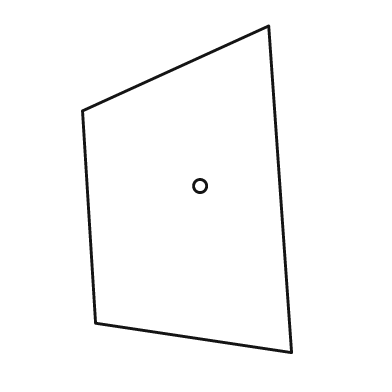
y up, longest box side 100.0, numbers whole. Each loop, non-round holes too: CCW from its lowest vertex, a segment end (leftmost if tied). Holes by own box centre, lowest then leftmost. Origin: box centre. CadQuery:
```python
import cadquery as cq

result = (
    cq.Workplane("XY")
    .moveTo(32.0, -50.0)
    .lineTo(25.0, 50.0)
    .lineTo(-32.0, 24.0)
    .lineTo(-28.0, -41.0)
    .close()
    .moveTo(4.0, 1.0)
    .circle(2.0)
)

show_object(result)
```